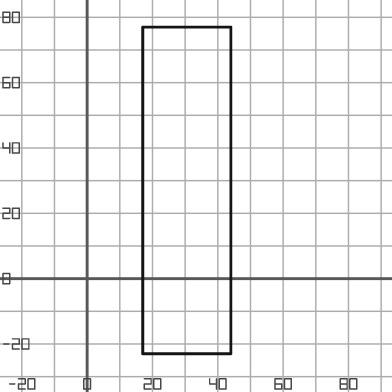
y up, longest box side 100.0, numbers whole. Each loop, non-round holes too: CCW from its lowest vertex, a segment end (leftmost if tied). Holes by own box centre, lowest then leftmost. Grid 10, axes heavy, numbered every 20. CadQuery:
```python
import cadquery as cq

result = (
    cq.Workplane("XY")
    .moveTo(17.0, -23.0)
    .lineTo(44.0, -23.0)
    .lineTo(44.0, 77.0)
    .lineTo(17.0, 77.0)
    .close()
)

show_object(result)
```